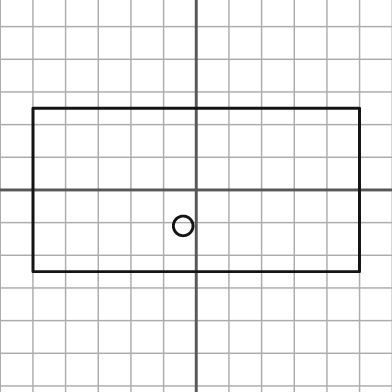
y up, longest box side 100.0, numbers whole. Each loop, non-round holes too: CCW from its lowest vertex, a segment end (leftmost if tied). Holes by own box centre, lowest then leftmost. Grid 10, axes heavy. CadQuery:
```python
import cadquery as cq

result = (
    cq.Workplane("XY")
    .moveTo(-50.0, -25.0)
    .lineTo(50.0, -25.0)
    .lineTo(50.0, 25.0)
    .lineTo(-50.0, 25.0)
    .close()
    .moveTo(-4.0, -11.0)
    .circle(3.0)
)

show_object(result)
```